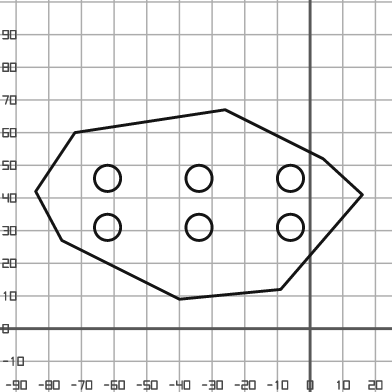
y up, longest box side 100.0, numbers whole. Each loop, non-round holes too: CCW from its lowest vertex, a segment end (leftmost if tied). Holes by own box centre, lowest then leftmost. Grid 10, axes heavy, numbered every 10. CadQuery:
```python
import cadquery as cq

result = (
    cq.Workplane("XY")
    .moveTo(-40.0, 9.0)
    .lineTo(-9.0, 12.0)
    .lineTo(16.0, 41.0)
    .lineTo(4.0, 52.0)
    .lineTo(-26.0, 67.0)
    .lineTo(-72.0, 60.0)
    .lineTo(-84.0, 42.0)
    .lineTo(-76.0, 27.0)
    .close()
    .moveTo(-62.0, 31.0)
    .circle(4.0)
    .moveTo(-34.0, 31.0)
    .circle(4.0)
    .moveTo(-6.0, 31.0)
    .circle(4.0)
    .moveTo(-62.0, 46.0)
    .circle(4.0)
    .moveTo(-34.0, 46.0)
    .circle(4.0)
    .moveTo(-6.0, 46.0)
    .circle(4.0)
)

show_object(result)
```